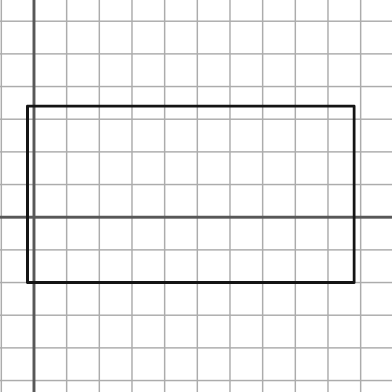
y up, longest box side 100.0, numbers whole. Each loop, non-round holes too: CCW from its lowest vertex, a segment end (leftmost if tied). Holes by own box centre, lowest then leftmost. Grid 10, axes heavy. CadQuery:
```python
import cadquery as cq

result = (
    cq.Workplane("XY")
    .moveTo(-2.0, -20.0)
    .lineTo(98.0, -20.0)
    .lineTo(98.0, 34.0)
    .lineTo(-2.0, 34.0)
    .close()
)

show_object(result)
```